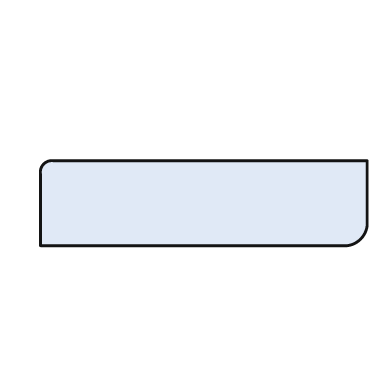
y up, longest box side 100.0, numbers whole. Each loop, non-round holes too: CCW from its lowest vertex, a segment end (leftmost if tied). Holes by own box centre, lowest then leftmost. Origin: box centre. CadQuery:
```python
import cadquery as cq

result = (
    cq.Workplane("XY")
    .moveTo(-50.0, -13.0)
    .lineTo(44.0, -13.0)
    .threePointArc((48.0, -11.0), (50.0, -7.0))
    .lineTo(50.0, 13.0)
    .lineTo(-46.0, 13.0)
    .threePointArc((-49.0, 12.0), (-50.0, 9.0))
    .close()
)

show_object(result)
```